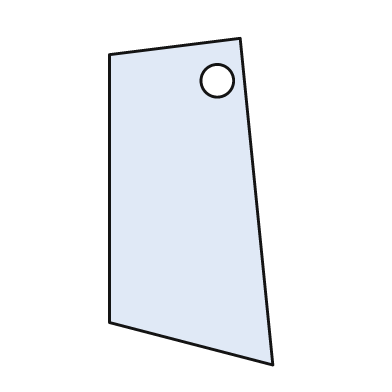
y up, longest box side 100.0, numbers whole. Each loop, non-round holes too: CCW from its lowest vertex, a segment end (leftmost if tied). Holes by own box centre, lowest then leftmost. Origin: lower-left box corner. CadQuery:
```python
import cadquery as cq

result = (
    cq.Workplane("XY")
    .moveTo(50.0, 0.0)
    .lineTo(40.0, 100.0)
    .lineTo(0.0, 95.0)
    .lineTo(0.0, 13.0)
    .close()
    .moveTo(33.0, 87.0)
    .circle(5.0)
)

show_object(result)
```